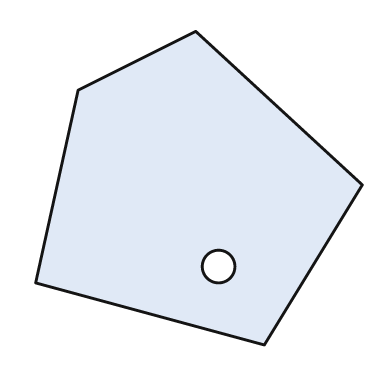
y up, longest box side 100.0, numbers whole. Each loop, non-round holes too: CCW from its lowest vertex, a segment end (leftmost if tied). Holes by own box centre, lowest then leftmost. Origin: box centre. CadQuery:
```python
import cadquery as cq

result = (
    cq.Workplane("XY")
    .moveTo(20.0, -48.0)
    .lineTo(50.0, 1.0)
    .lineTo(-1.0, 48.0)
    .lineTo(-37.0, 30.0)
    .lineTo(-50.0, -29.0)
    .close()
    .moveTo(6.0, -24.0)
    .circle(5.0)
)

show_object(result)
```